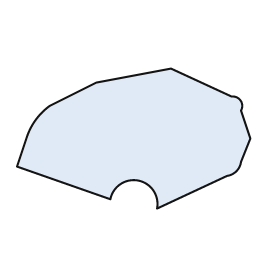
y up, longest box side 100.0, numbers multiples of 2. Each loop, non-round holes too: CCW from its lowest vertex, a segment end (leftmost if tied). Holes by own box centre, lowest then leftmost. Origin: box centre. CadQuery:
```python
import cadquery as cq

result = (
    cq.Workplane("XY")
    .moveTo(10.0, -30.0)
    .lineTo(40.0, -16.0)
    .threePointArc((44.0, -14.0), (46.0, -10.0))
    .lineTo(50.0, 0.0)
    .lineTo(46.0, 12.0)
    .threePointArc((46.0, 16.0), (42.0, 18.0))
    .lineTo(16.0, 30.0)
    .lineTo(-16.0, 24.0)
    .lineTo(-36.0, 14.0)
    .threePointArc((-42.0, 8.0), (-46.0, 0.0))
    .lineTo(-50.0, -12.0)
    .lineTo(-10.0, -26.0)
    .threePointArc((2.0, -18.0), (10.0, -30.0))
    .close()
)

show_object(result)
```